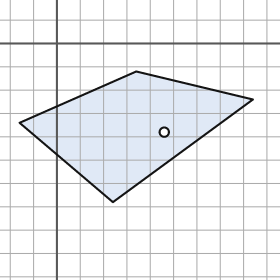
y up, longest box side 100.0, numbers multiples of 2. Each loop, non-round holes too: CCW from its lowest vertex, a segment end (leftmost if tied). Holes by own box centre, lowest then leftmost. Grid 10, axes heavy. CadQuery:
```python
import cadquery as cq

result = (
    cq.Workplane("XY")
    .moveTo(24.0, -68.0)
    .lineTo(84.0, -24.0)
    .lineTo(34.0, -12.0)
    .lineTo(-16.0, -34.0)
    .close()
    .moveTo(46.0, -38.0)
    .circle(2.0)
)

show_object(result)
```